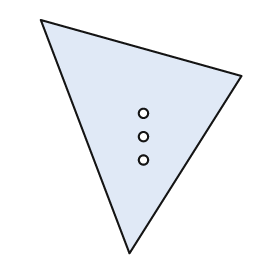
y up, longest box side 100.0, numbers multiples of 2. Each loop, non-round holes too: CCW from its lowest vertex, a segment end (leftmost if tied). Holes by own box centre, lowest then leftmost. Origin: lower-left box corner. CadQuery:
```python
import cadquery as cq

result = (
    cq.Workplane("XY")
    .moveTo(38.0, 0.0)
    .lineTo(86.0, 76.0)
    .lineTo(0.0, 100.0)
    .close()
    .moveTo(44.0, 40.0)
    .circle(2.0)
    .moveTo(44.0, 50.0)
    .circle(2.0)
    .moveTo(44.0, 60.0)
    .circle(2.0)
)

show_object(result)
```